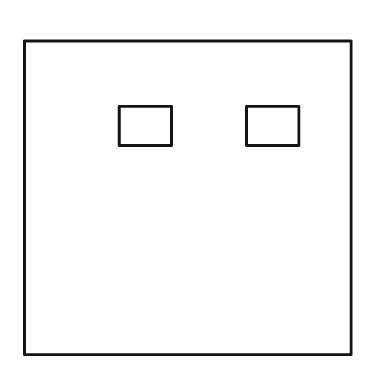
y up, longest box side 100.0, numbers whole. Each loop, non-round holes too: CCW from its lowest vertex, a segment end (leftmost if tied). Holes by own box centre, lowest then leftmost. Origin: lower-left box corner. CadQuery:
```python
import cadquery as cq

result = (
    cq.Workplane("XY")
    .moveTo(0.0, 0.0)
    .lineTo(100.0, 0.0)
    .lineTo(100.0, 96.0)
    .lineTo(0.0, 96.0)
    .close()
    .moveTo(29.0, 64.0)
    .lineTo(45.0, 64.0)
    .lineTo(45.0, 76.0)
    .lineTo(29.0, 76.0)
    .close()
    .moveTo(68.0, 64.0)
    .lineTo(84.0, 64.0)
    .lineTo(84.0, 76.0)
    .lineTo(68.0, 76.0)
    .close()
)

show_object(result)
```